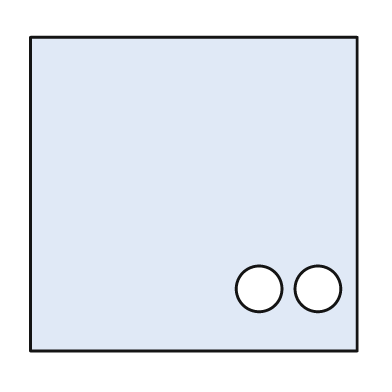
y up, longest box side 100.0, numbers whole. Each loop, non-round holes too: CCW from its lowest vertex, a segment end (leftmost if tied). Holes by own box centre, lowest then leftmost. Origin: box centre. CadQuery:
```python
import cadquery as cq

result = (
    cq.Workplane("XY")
    .moveTo(-50.0, -48.0)
    .lineTo(50.0, -48.0)
    .lineTo(50.0, 48.0)
    .lineTo(-50.0, 48.0)
    .close()
    .moveTo(20.0, -29.0)
    .circle(7.0)
    .moveTo(38.0, -29.0)
    .circle(7.0)
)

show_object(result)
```